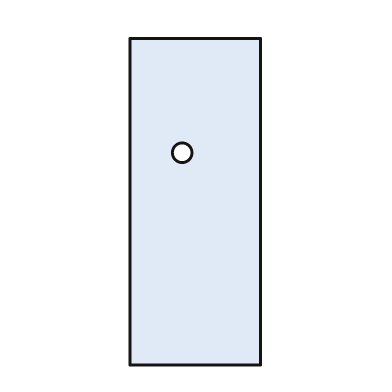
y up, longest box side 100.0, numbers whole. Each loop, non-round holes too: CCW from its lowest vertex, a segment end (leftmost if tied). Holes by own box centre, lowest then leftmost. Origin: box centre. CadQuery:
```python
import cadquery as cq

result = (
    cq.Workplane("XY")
    .moveTo(-20.0, -50.0)
    .lineTo(20.0, -50.0)
    .lineTo(20.0, 50.0)
    .lineTo(-20.0, 50.0)
    .close()
    .moveTo(-4.0, 15.0)
    .circle(3.0)
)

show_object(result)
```